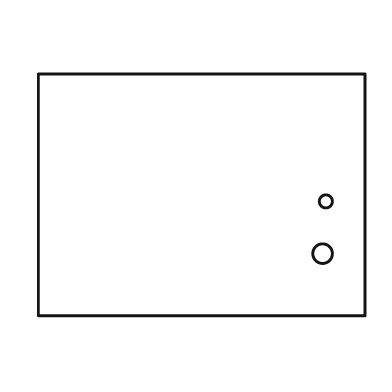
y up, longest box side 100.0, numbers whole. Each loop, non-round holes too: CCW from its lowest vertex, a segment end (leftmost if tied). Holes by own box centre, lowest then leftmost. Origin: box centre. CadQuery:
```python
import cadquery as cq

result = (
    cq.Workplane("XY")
    .moveTo(-50.0, -37.0)
    .lineTo(50.0, -37.0)
    .lineTo(50.0, 37.0)
    .lineTo(-50.0, 37.0)
    .close()
    .moveTo(37.0, -18.0)
    .circle(3.0)
    .moveTo(38.0, -2.0)
    .circle(2.0)
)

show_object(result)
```